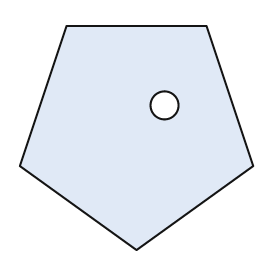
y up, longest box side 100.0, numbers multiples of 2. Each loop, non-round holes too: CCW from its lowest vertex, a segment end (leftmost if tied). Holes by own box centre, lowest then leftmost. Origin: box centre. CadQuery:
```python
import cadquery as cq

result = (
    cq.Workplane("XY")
    .moveTo(0.0, -48.0)
    .lineTo(50.0, -12.0)
    .lineTo(30.0, 48.0)
    .lineTo(-30.0, 48.0)
    .lineTo(-50.0, -12.0)
    .close()
    .moveTo(12.0, 14.0)
    .circle(6.0)
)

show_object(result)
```